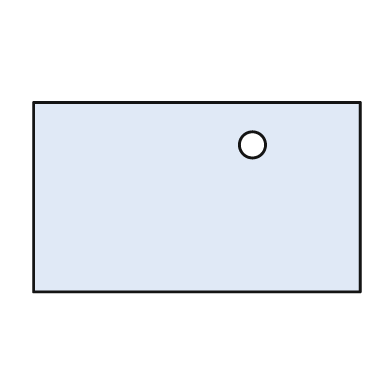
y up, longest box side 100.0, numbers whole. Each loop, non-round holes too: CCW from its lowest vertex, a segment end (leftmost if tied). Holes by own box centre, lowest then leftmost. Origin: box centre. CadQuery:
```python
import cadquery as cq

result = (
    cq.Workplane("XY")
    .moveTo(-50.0, -29.0)
    .lineTo(50.0, -29.0)
    .lineTo(50.0, 29.0)
    .lineTo(-50.0, 29.0)
    .close()
    .moveTo(17.0, 16.0)
    .circle(4.0)
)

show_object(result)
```